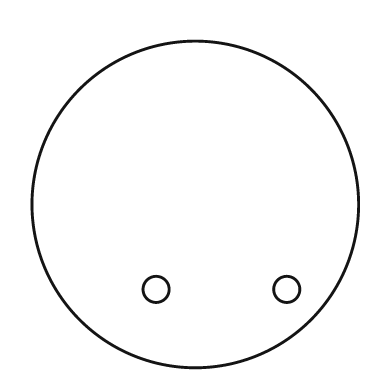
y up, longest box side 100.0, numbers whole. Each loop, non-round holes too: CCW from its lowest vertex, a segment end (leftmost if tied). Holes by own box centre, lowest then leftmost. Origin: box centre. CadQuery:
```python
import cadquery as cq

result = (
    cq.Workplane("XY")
    .moveTo(0.0, 0.0)
    .circle(50.0)
    .moveTo(-12.0, -26.0)
    .circle(4.0)
    .moveTo(28.0, -26.0)
    .circle(4.0)
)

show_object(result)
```